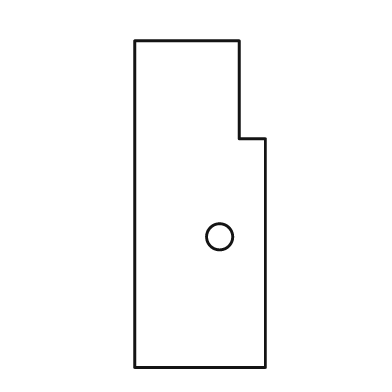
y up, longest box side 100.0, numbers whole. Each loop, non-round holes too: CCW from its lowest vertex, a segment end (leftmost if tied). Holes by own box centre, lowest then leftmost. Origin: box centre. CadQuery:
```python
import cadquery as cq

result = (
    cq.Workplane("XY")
    .moveTo(-20.0, -50.0)
    .lineTo(20.0, -50.0)
    .lineTo(20.0, 20.0)
    .lineTo(12.0, 20.0)
    .lineTo(12.0, 50.0)
    .lineTo(-20.0, 50.0)
    .close()
    .moveTo(6.0, -10.0)
    .circle(4.0)
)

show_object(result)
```